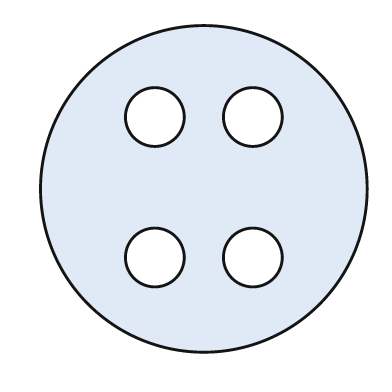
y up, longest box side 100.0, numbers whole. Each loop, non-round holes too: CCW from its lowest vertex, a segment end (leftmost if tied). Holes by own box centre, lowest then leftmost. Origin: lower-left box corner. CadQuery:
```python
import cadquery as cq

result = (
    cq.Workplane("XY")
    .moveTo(50.0, 50.0)
    .circle(50.0)
    .moveTo(35.0, 29.0)
    .circle(9.0)
    .moveTo(65.0, 29.0)
    .circle(9.0)
    .moveTo(35.0, 72.0)
    .circle(9.0)
    .moveTo(65.0, 72.0)
    .circle(9.0)
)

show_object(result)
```